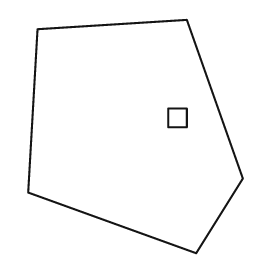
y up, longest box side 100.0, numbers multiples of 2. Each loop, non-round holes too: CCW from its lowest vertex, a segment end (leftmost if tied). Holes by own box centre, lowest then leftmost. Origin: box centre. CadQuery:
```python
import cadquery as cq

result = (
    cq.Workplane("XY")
    .moveTo(26.0, -50.0)
    .lineTo(46.0, -18.0)
    .lineTo(22.0, 50.0)
    .lineTo(-42.0, 46.0)
    .lineTo(-46.0, -24.0)
    .close()
    .moveTo(14.0, 4.0)
    .lineTo(22.0, 4.0)
    .lineTo(22.0, 12.0)
    .lineTo(14.0, 12.0)
    .close()
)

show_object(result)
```